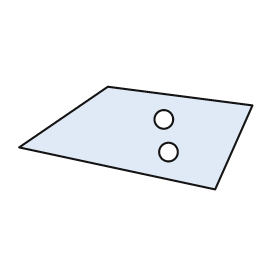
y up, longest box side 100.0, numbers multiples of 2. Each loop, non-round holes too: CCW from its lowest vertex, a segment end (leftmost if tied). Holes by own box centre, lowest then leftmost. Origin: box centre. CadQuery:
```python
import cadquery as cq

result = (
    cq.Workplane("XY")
    .moveTo(34.0, -22.0)
    .lineTo(50.0, 14.0)
    .lineTo(-12.0, 22.0)
    .lineTo(-50.0, -4.0)
    .close()
    .moveTo(14.0, -6.0)
    .circle(4.0)
    .moveTo(12.0, 8.0)
    .circle(4.0)
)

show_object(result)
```